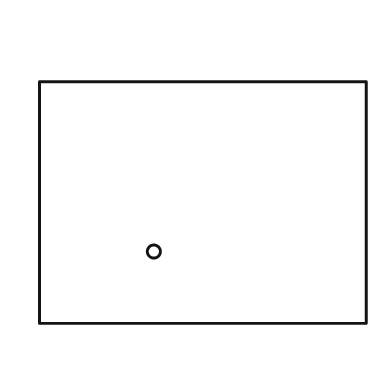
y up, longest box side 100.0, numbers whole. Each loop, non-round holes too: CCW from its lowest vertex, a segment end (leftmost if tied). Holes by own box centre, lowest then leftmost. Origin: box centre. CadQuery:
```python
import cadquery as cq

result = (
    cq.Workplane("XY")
    .moveTo(-50.0, -37.0)
    .lineTo(50.0, -37.0)
    .lineTo(50.0, 37.0)
    .lineTo(-50.0, 37.0)
    .close()
    .moveTo(-15.0, -15.0)
    .circle(2.0)
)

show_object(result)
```